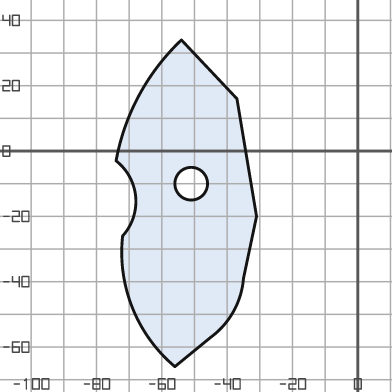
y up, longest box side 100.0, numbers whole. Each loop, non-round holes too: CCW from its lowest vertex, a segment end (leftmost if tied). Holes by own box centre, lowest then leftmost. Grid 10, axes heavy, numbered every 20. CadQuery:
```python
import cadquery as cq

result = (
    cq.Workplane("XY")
    .moveTo(-56.0, -66.0)
    .lineTo(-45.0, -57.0)
    .threePointArc((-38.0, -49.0), (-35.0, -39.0))
    .lineTo(-31.0, -20.0)
    .lineTo(-37.0, 16.0)
    .lineTo(-54.0, 34.0)
    .threePointArc((-67.0, 17.0), (-74.0, -3.0))
    .threePointArc((-68.0, -14.0), (-72.0, -26.0))
    .threePointArc((-69.0, -48.0), (-56.0, -66.0))
    .close()
    .moveTo(-51.0, -10.0)
    .circle(5.0)
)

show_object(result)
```